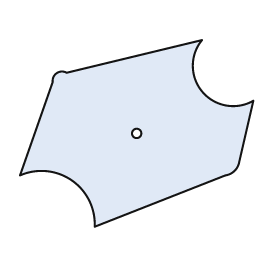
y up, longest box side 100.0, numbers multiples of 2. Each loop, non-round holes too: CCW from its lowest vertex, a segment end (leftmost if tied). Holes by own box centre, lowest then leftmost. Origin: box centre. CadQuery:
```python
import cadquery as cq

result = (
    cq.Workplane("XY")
    .moveTo(-18.0, -40.0)
    .lineTo(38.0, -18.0)
    .threePointArc((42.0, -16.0), (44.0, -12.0))
    .lineTo(50.0, 14.0)
    .threePointArc((28.0, 18.0), (28.0, 40.0))
    .lineTo(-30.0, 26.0)
    .threePointArc((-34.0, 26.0), (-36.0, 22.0))
    .lineTo(-50.0, -18.0)
    .threePointArc((-28.0, -20.0), (-18.0, -40.0))
    .close()
    .moveTo(0.0, 0.0)
    .circle(2.0)
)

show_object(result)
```